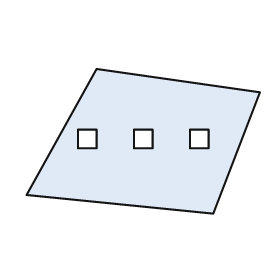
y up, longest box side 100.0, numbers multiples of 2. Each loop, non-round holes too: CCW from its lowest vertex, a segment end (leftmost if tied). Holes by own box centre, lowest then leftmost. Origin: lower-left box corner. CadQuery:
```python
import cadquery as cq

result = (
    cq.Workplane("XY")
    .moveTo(80.0, 0.0)
    .lineTo(100.0, 52.0)
    .lineTo(30.0, 62.0)
    .lineTo(0.0, 8.0)
    .close()
    .moveTo(22.0, 28.0)
    .lineTo(30.0, 28.0)
    .lineTo(30.0, 36.0)
    .lineTo(22.0, 36.0)
    .close()
    .moveTo(46.0, 28.0)
    .lineTo(54.0, 28.0)
    .lineTo(54.0, 36.0)
    .lineTo(46.0, 36.0)
    .close()
    .moveTo(70.0, 28.0)
    .lineTo(78.0, 28.0)
    .lineTo(78.0, 36.0)
    .lineTo(70.0, 36.0)
    .close()
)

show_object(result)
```